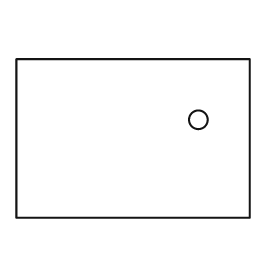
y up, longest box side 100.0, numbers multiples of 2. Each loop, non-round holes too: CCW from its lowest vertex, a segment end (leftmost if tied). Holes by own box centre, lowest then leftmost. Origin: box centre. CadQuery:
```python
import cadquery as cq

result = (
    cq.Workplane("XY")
    .moveTo(-50.0, -34.0)
    .lineTo(50.0, -34.0)
    .lineTo(50.0, 34.0)
    .lineTo(-50.0, 34.0)
    .close()
    .moveTo(28.0, 8.0)
    .circle(4.0)
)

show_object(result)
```